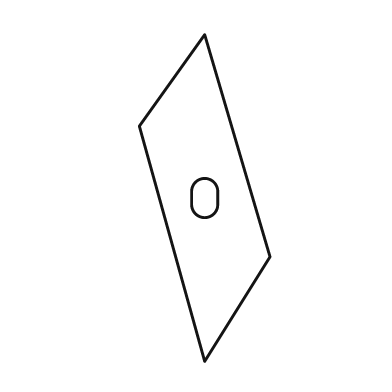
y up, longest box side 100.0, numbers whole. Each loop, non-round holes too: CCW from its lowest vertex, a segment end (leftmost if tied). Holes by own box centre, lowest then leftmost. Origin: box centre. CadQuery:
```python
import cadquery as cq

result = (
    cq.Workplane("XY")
    .moveTo(0.0, -50.0)
    .lineTo(20.0, -18.0)
    .lineTo(0.0, 50.0)
    .lineTo(-20.0, 22.0)
    .close()
    .moveTo(-4.0, -2.0)
    .threePointArc((0.0, -6.0), (4.0, -2.0))
    .lineTo(4.0, 2.0)
    .threePointArc((0.0, 6.0), (-4.0, 2.0))
    .close()
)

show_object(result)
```